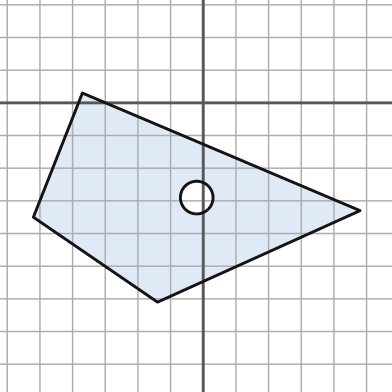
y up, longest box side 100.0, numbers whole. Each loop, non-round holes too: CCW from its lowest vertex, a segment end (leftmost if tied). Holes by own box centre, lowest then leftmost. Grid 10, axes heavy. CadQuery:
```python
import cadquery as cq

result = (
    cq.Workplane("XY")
    .moveTo(-14.0, -61.0)
    .lineTo(48.0, -33.0)
    .lineTo(-37.0, 3.0)
    .lineTo(-52.0, -35.0)
    .close()
    .moveTo(-2.0, -29.0)
    .circle(5.0)
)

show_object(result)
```